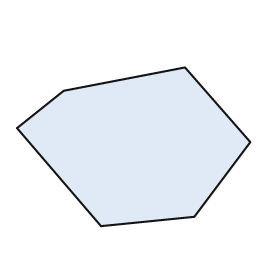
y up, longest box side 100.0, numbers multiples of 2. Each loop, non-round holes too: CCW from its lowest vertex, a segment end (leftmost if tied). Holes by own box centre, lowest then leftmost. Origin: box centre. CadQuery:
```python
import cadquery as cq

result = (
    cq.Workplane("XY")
    .moveTo(-14.0, -34.0)
    .lineTo(26.0, -30.0)
    .lineTo(50.0, 2.0)
    .lineTo(22.0, 34.0)
    .lineTo(-30.0, 24.0)
    .lineTo(-50.0, 8.0)
    .close()
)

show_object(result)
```